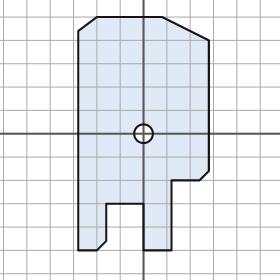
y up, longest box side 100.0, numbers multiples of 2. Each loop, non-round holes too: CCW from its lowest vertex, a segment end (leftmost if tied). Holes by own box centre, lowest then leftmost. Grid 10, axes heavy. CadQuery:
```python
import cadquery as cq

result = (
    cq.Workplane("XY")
    .moveTo(-28.0, -50.0)
    .lineTo(-20.0, -50.0)
    .lineTo(-16.0, -46.0)
    .lineTo(-16.0, -30.0)
    .lineTo(0.0, -30.0)
    .lineTo(0.0, -50.0)
    .lineTo(12.0, -50.0)
    .lineTo(12.0, -20.0)
    .lineTo(24.0, -20.0)
    .lineTo(28.0, -16.0)
    .lineTo(28.0, 40.0)
    .lineTo(8.0, 50.0)
    .lineTo(-20.0, 50.0)
    .lineTo(-28.0, 44.0)
    .close()
    .moveTo(0.0, 0.0)
    .circle(4.0)
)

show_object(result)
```